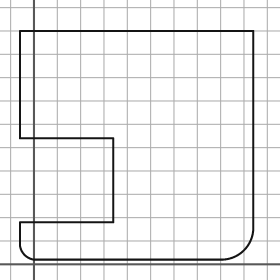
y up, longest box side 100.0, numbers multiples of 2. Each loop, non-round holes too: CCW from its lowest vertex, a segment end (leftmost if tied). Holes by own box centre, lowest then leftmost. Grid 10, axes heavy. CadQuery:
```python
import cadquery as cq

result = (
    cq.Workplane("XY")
    .moveTo(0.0, 2.0)
    .lineTo(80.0, 2.0)
    .threePointArc((90.0, 6.0), (94.0, 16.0))
    .lineTo(94.0, 100.0)
    .lineTo(-6.0, 100.0)
    .lineTo(-6.0, 54.0)
    .lineTo(34.0, 54.0)
    .lineTo(34.0, 18.0)
    .lineTo(-6.0, 18.0)
    .lineTo(-6.0, 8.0)
    .threePointArc((-4.0, 4.0), (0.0, 2.0))
    .close()
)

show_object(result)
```